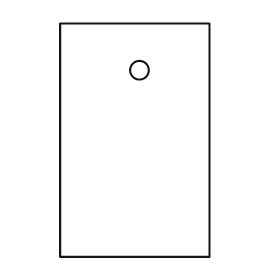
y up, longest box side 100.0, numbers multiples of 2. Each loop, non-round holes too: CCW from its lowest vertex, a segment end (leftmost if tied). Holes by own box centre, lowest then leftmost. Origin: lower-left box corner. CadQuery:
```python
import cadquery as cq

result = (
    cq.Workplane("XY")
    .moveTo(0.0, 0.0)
    .lineTo(64.0, 0.0)
    .lineTo(64.0, 100.0)
    .lineTo(0.0, 100.0)
    .close()
    .moveTo(34.0, 80.0)
    .circle(4.0)
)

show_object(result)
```